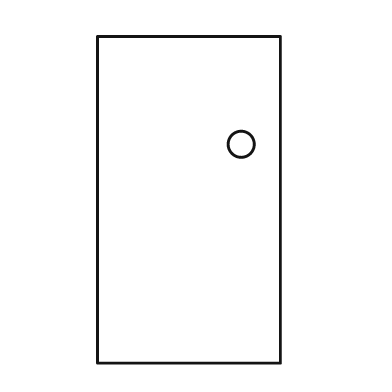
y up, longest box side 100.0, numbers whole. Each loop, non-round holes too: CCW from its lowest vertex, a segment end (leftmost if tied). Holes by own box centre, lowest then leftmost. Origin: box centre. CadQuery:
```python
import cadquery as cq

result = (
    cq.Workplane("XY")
    .moveTo(-28.0, -50.0)
    .lineTo(28.0, -50.0)
    .lineTo(28.0, 50.0)
    .lineTo(-28.0, 50.0)
    .close()
    .moveTo(16.0, 17.0)
    .circle(4.0)
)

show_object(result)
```